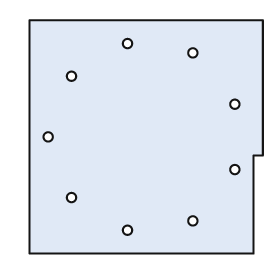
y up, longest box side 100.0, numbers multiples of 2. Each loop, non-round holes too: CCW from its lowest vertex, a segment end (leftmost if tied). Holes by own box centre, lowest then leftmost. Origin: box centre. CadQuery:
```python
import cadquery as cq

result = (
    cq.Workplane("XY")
    .moveTo(-50.0, -50.0)
    .lineTo(46.0, -50.0)
    .lineTo(46.0, -8.0)
    .lineTo(50.0, -8.0)
    .lineTo(50.0, 50.0)
    .lineTo(-50.0, 50.0)
    .close()
    .moveTo(-8.0, -40.0)
    .circle(2.0)
    .moveTo(20.0, -36.0)
    .circle(2.0)
    .moveTo(-32.0, -26.0)
    .circle(2.0)
    .moveTo(38.0, -14.0)
    .circle(2.0)
    .moveTo(-42.0, 0.0)
    .circle(2.0)
    .moveTo(38.0, 14.0)
    .circle(2.0)
    .moveTo(-32.0, 26.0)
    .circle(2.0)
    .moveTo(20.0, 36.0)
    .circle(2.0)
    .moveTo(-8.0, 40.0)
    .circle(2.0)
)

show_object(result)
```